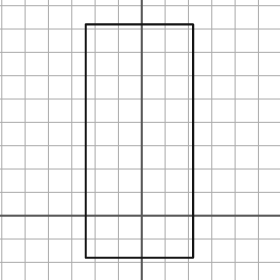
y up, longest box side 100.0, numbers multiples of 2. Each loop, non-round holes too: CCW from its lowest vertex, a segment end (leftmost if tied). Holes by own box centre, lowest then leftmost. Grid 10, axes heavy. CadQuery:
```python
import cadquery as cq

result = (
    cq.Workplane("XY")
    .moveTo(-24.0, -18.0)
    .lineTo(22.0, -18.0)
    .lineTo(22.0, 82.0)
    .lineTo(-24.0, 82.0)
    .close()
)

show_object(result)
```